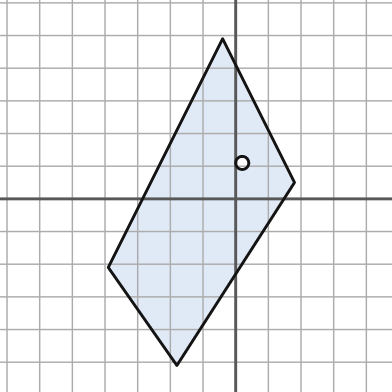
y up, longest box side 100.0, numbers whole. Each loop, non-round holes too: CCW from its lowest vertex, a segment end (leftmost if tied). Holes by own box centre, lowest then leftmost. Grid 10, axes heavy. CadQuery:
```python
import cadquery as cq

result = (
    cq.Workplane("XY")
    .moveTo(-18.0, -51.0)
    .lineTo(18.0, 5.0)
    .lineTo(-4.0, 49.0)
    .lineTo(-39.0, -21.0)
    .close()
    .moveTo(2.0, 11.0)
    .circle(2.0)
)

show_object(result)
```